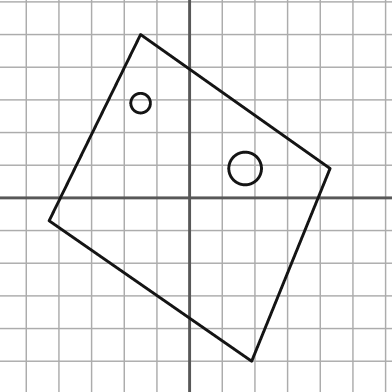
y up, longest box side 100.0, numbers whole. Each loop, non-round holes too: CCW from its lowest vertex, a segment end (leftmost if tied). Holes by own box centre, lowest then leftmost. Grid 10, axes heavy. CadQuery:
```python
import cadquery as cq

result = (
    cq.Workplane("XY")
    .moveTo(19.0, -50.0)
    .lineTo(43.0, 9.0)
    .lineTo(-15.0, 50.0)
    .lineTo(-43.0, -7.0)
    .close()
    .moveTo(17.0, 9.0)
    .circle(5.0)
    .moveTo(-15.0, 29.0)
    .circle(3.0)
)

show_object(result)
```